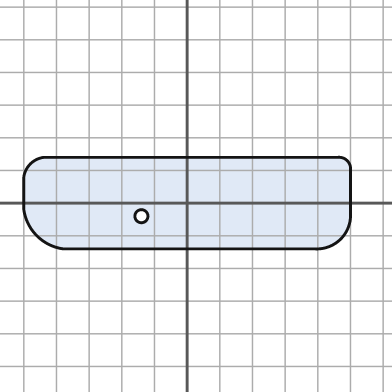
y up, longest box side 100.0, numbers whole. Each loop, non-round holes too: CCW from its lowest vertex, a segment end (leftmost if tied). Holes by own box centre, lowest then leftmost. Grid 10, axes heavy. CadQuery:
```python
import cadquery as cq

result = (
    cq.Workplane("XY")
    .moveTo(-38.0, -14.0)
    .lineTo(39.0, -14.0)
    .threePointArc((47.0, -11.0), (50.0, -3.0))
    .lineTo(50.0, 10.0)
    .threePointArc((49.0, 13.0), (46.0, 14.0))
    .lineTo(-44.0, 14.0)
    .threePointArc((-48.0, 12.0), (-50.0, 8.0))
    .lineTo(-50.0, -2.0)
    .threePointArc((-46.0, -10.0), (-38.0, -14.0))
    .close()
    .moveTo(-14.0, -4.0)
    .circle(2.0)
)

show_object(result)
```